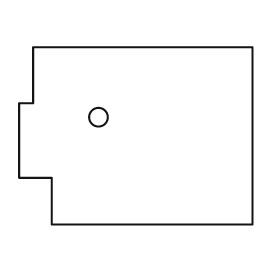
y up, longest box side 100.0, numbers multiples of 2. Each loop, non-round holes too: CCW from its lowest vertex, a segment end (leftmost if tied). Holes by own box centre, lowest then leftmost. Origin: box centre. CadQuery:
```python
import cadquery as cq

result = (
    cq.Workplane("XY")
    .moveTo(-36.0, -38.0)
    .lineTo(50.0, -38.0)
    .lineTo(50.0, 38.0)
    .lineTo(-44.0, 38.0)
    .lineTo(-44.0, 14.0)
    .lineTo(-50.0, 14.0)
    .lineTo(-50.0, -18.0)
    .lineTo(-36.0, -18.0)
    .close()
    .moveTo(-16.0, 8.0)
    .circle(4.0)
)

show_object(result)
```